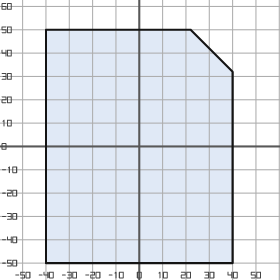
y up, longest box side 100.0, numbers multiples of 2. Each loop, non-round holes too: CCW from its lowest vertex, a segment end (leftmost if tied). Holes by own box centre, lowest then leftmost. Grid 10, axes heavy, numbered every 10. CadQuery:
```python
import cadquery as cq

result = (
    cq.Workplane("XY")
    .moveTo(-40.0, -50.0)
    .lineTo(40.0, -50.0)
    .lineTo(40.0, 32.0)
    .lineTo(22.0, 50.0)
    .lineTo(-40.0, 50.0)
    .close()
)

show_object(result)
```